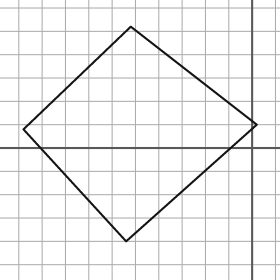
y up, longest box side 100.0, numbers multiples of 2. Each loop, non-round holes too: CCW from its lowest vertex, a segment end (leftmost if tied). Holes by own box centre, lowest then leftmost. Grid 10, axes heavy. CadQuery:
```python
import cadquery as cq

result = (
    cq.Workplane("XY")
    .moveTo(-54.0, -40.0)
    .lineTo(2.0, 10.0)
    .lineTo(-52.0, 52.0)
    .lineTo(-98.0, 8.0)
    .close()
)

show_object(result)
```